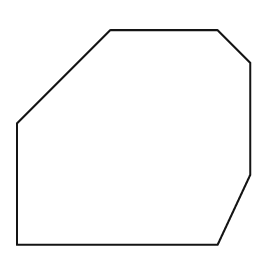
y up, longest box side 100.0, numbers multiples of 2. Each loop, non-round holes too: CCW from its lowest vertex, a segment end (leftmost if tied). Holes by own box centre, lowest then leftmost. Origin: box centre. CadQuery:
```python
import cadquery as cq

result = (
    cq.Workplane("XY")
    .moveTo(-50.0, -46.0)
    .lineTo(36.0, -46.0)
    .lineTo(50.0, -16.0)
    .lineTo(50.0, 32.0)
    .lineTo(36.0, 46.0)
    .lineTo(-10.0, 46.0)
    .lineTo(-50.0, 6.0)
    .close()
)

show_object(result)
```